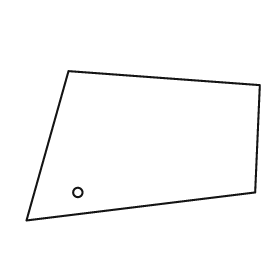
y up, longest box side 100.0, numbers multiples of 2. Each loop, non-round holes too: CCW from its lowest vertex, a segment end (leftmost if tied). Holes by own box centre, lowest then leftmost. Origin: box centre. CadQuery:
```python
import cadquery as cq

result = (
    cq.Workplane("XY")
    .moveTo(-50.0, -32.0)
    .lineTo(48.0, -20.0)
    .lineTo(50.0, 26.0)
    .lineTo(-32.0, 32.0)
    .close()
    .moveTo(-28.0, -20.0)
    .circle(2.0)
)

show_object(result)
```